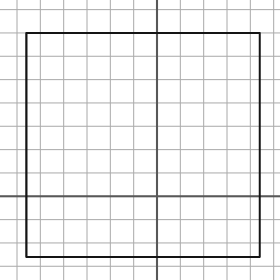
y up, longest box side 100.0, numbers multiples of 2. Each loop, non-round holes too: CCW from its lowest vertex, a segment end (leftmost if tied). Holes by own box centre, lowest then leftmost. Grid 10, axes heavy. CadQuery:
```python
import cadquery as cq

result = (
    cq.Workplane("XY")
    .moveTo(-56.0, -26.0)
    .lineTo(44.0, -26.0)
    .lineTo(44.0, 70.0)
    .lineTo(-56.0, 70.0)
    .close()
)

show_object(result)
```